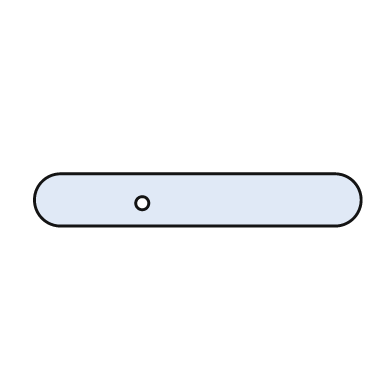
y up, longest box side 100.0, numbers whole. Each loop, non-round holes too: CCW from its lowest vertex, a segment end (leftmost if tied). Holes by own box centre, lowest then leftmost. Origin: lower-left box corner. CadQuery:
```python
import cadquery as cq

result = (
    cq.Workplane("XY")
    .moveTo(8.0, 0.0)
    .lineTo(92.0, 0.0)
    .threePointArc((100.0, 8.0), (92.0, 16.0))
    .lineTo(8.0, 16.0)
    .threePointArc((0.0, 8.0), (8.0, 0.0))
    .close()
    .moveTo(33.0, 7.0)
    .circle(2.0)
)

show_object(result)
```